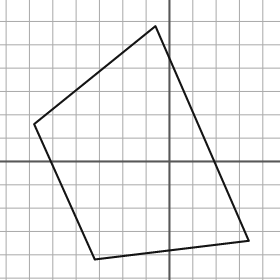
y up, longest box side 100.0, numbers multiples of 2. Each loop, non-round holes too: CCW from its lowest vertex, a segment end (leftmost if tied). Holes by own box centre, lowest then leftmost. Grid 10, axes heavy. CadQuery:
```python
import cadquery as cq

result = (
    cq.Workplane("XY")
    .moveTo(-32.0, -42.0)
    .lineTo(34.0, -34.0)
    .lineTo(-6.0, 58.0)
    .lineTo(-58.0, 16.0)
    .close()
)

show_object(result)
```